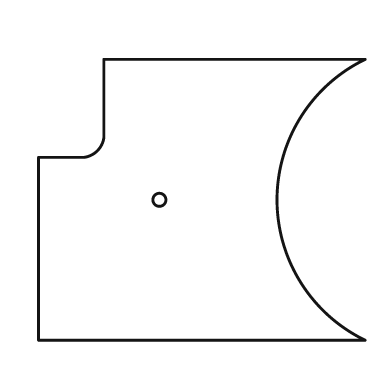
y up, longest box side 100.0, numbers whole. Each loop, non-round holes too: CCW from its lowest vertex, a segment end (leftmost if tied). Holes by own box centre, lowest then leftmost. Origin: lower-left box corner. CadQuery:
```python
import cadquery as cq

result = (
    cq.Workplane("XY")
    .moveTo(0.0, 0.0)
    .lineTo(100.0, 0.0)
    .threePointArc((73.0, 43.0), (100.0, 86.0))
    .lineTo(20.0, 86.0)
    .lineTo(20.0, 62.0)
    .threePointArc((18.0, 58.0), (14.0, 56.0))
    .lineTo(0.0, 56.0)
    .close()
    .moveTo(37.0, 43.0)
    .circle(2.0)
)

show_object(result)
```